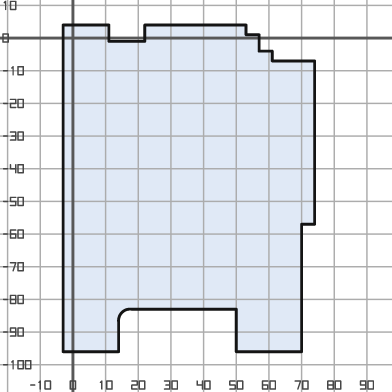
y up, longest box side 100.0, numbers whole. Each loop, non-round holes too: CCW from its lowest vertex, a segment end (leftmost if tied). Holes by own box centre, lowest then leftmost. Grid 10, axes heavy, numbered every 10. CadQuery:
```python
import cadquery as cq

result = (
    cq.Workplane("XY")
    .moveTo(-3.0, -96.0)
    .lineTo(14.0, -96.0)
    .lineTo(14.0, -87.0)
    .threePointArc((15.0, -84.0), (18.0, -83.0))
    .lineTo(50.0, -83.0)
    .lineTo(50.0, -96.0)
    .lineTo(70.0, -96.0)
    .lineTo(70.0, -57.0)
    .lineTo(74.0, -57.0)
    .lineTo(74.0, -7.0)
    .lineTo(61.0, -7.0)
    .lineTo(61.0, -4.0)
    .lineTo(57.0, -4.0)
    .lineTo(57.0, 1.0)
    .lineTo(53.0, 1.0)
    .lineTo(53.0, 4.0)
    .lineTo(22.0, 4.0)
    .lineTo(22.0, -1.0)
    .lineTo(11.0, -1.0)
    .lineTo(11.0, 4.0)
    .lineTo(-3.0, 4.0)
    .close()
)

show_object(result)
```